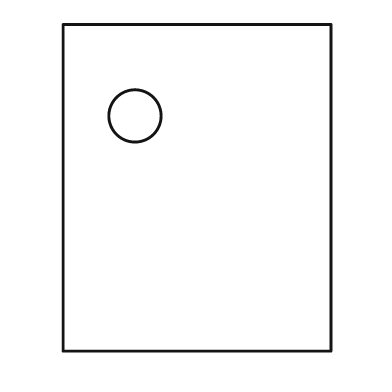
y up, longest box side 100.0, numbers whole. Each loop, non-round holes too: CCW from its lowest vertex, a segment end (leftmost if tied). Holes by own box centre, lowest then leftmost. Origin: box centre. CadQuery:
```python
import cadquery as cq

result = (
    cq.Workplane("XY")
    .moveTo(-41.0, -50.0)
    .lineTo(41.0, -50.0)
    .lineTo(41.0, 50.0)
    .lineTo(-41.0, 50.0)
    .close()
    .moveTo(-19.0, 22.0)
    .circle(8.0)
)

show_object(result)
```